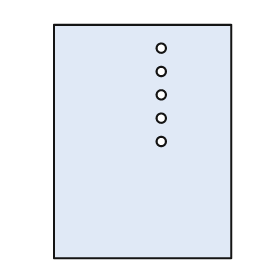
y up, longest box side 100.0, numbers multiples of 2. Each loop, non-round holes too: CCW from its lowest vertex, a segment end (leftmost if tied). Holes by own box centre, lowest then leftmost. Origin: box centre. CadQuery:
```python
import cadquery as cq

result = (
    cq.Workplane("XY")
    .moveTo(-38.0, -50.0)
    .lineTo(38.0, -50.0)
    .lineTo(38.0, 50.0)
    .lineTo(-38.0, 50.0)
    .close()
    .moveTo(8.0, 0.0)
    .circle(2.0)
    .moveTo(8.0, 10.0)
    .circle(2.0)
    .moveTo(8.0, 20.0)
    .circle(2.0)
    .moveTo(8.0, 30.0)
    .circle(2.0)
    .moveTo(8.0, 40.0)
    .circle(2.0)
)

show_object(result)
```